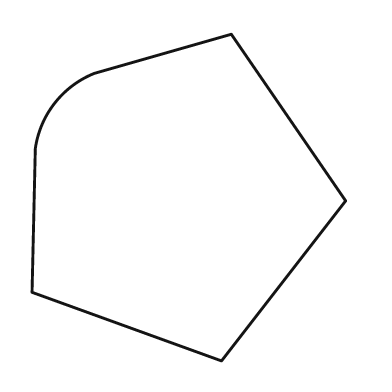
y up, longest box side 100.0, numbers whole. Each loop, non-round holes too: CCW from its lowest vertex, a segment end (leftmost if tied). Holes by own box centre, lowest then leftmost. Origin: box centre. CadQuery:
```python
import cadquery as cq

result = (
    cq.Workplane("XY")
    .moveTo(10.0, -50.0)
    .lineTo(48.0, -1.0)
    .lineTo(13.0, 50.0)
    .lineTo(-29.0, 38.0)
    .threePointArc((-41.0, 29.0), (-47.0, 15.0))
    .lineTo(-48.0, -29.0)
    .close()
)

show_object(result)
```